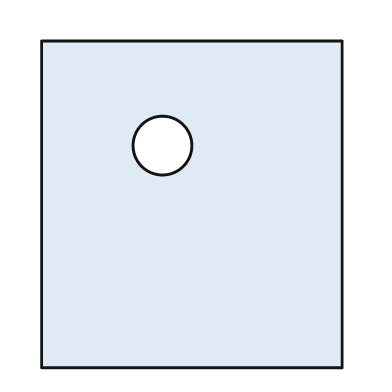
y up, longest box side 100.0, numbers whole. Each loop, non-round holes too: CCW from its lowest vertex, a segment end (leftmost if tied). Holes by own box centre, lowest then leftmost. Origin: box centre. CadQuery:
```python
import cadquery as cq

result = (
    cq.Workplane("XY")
    .moveTo(-46.0, -50.0)
    .lineTo(46.0, -50.0)
    .lineTo(46.0, 50.0)
    .lineTo(-46.0, 50.0)
    .close()
    .moveTo(-9.0, 18.0)
    .circle(9.0)
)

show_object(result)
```